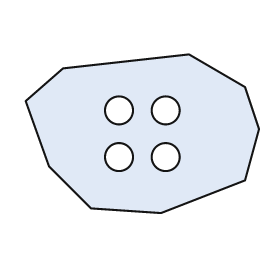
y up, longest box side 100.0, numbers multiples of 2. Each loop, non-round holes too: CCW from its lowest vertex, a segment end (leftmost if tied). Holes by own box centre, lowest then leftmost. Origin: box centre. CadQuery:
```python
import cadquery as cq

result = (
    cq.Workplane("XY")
    .moveTo(8.0, -34.0)
    .lineTo(44.0, -20.0)
    .lineTo(50.0, 2.0)
    .lineTo(44.0, 20.0)
    .lineTo(20.0, 34.0)
    .lineTo(-34.0, 28.0)
    .lineTo(-50.0, 14.0)
    .lineTo(-40.0, -14.0)
    .lineTo(-22.0, -32.0)
    .close()
    .moveTo(-10.0, -10.0)
    .circle(6.0)
    .moveTo(10.0, -10.0)
    .circle(6.0)
    .moveTo(-10.0, 10.0)
    .circle(6.0)
    .moveTo(10.0, 10.0)
    .circle(6.0)
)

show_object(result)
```